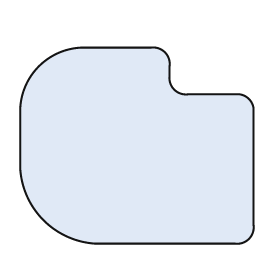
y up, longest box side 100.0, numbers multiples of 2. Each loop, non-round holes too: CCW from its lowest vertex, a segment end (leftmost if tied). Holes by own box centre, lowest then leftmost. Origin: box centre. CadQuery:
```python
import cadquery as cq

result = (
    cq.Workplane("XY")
    .moveTo(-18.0, -42.0)
    .lineTo(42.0, -42.0)
    .threePointArc((48.0, -40.0), (50.0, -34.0))
    .lineTo(50.0, 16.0)
    .threePointArc((48.0, 20.0), (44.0, 22.0))
    .lineTo(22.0, 22.0)
    .threePointArc((16.0, 24.0), (14.0, 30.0))
    .lineTo(14.0, 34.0)
    .threePointArc((12.0, 40.0), (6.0, 42.0))
    .lineTo(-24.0, 42.0)
    .threePointArc((-42.0, 34.0), (-50.0, 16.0))
    .lineTo(-50.0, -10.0)
    .threePointArc((-40.0, -32.0), (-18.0, -42.0))
    .close()
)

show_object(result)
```